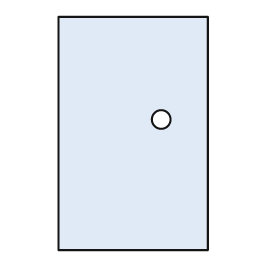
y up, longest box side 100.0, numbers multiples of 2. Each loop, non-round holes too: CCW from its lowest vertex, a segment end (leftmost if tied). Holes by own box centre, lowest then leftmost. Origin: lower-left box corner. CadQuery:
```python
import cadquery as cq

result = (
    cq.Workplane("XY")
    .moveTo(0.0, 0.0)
    .lineTo(64.0, 0.0)
    .lineTo(64.0, 100.0)
    .lineTo(0.0, 100.0)
    .close()
    .moveTo(44.0, 56.0)
    .circle(4.0)
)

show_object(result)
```